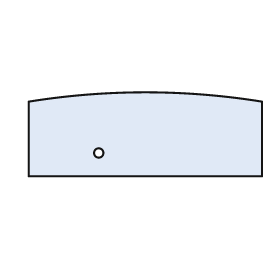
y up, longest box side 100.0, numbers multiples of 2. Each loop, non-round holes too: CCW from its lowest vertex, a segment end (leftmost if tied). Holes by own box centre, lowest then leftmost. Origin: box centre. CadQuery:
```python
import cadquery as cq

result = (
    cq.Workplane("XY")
    .moveTo(-50.0, -18.0)
    .lineTo(50.0, -18.0)
    .lineTo(50.0, 14.0)
    .threePointArc((0.0, 18.0), (-50.0, 14.0))
    .close()
    .moveTo(-20.0, -8.0)
    .circle(2.0)
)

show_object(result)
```